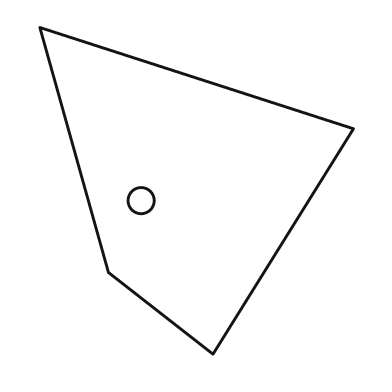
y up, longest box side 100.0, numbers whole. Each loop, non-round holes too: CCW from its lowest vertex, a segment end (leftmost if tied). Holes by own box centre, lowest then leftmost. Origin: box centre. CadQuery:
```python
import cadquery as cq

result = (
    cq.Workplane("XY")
    .moveTo(5.0, -50.0)
    .lineTo(48.0, 19.0)
    .lineTo(-48.0, 50.0)
    .lineTo(-27.0, -25.0)
    .close()
    .moveTo(-17.0, -3.0)
    .circle(4.0)
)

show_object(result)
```